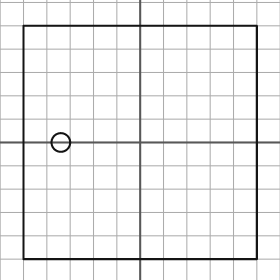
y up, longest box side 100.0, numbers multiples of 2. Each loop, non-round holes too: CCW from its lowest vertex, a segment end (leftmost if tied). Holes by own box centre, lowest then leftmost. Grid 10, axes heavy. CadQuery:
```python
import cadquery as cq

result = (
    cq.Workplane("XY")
    .moveTo(-50.0, -50.0)
    .lineTo(50.0, -50.0)
    .lineTo(50.0, 50.0)
    .lineTo(-50.0, 50.0)
    .close()
    .moveTo(-34.0, 0.0)
    .circle(4.0)
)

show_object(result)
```